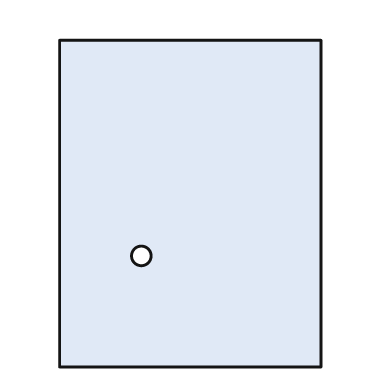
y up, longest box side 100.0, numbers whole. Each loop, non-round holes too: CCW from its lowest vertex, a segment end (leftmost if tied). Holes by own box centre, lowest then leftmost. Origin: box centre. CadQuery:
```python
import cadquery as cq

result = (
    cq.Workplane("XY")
    .moveTo(-40.0, -50.0)
    .lineTo(40.0, -50.0)
    .lineTo(40.0, 50.0)
    .lineTo(-40.0, 50.0)
    .close()
    .moveTo(-15.0, -16.0)
    .circle(3.0)
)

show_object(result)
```